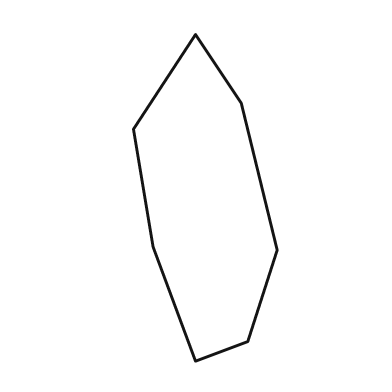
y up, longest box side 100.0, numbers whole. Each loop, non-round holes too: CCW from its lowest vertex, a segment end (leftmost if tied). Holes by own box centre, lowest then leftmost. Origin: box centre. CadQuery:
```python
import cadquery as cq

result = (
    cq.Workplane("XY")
    .moveTo(-3.0, -50.0)
    .lineTo(13.0, -44.0)
    .lineTo(22.0, -16.0)
    .lineTo(11.0, 29.0)
    .lineTo(-3.0, 50.0)
    .lineTo(-22.0, 21.0)
    .lineTo(-16.0, -15.0)
    .close()
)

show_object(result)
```